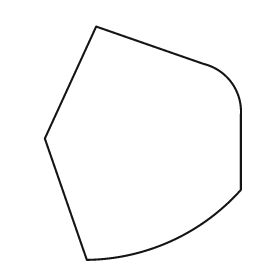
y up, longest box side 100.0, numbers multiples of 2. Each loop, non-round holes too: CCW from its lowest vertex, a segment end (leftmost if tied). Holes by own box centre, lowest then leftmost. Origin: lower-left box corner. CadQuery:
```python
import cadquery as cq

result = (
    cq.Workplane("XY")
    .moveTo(18.0, 0.0)
    .threePointArc((54.0, 8.0), (84.0, 30.0))
    .lineTo(84.0, 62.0)
    .threePointArc((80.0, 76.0), (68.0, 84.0))
    .lineTo(22.0, 100.0)
    .lineTo(0.0, 52.0)
    .close()
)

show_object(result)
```